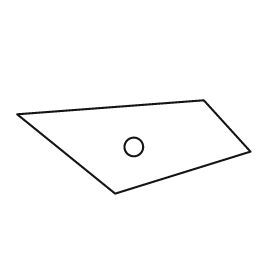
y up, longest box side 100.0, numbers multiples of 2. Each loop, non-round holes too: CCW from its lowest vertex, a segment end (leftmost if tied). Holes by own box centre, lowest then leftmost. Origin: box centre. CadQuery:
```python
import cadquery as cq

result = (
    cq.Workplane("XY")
    .moveTo(-8.0, -20.0)
    .lineTo(50.0, -2.0)
    .lineTo(30.0, 20.0)
    .lineTo(-50.0, 14.0)
    .close()
    .moveTo(0.0, 0.0)
    .circle(4.0)
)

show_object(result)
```